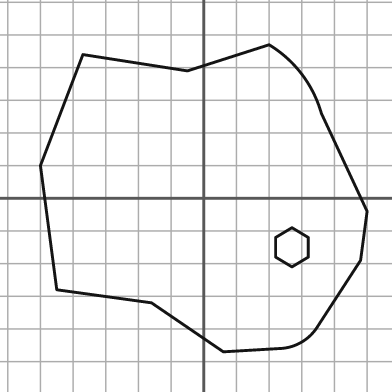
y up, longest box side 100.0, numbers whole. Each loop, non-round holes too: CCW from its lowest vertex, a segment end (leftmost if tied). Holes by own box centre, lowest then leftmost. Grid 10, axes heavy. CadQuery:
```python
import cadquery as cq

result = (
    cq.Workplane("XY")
    .moveTo(6.0, -47.0)
    .lineTo(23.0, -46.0)
    .threePointArc((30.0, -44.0), (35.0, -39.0))
    .lineTo(48.0, -19.0)
    .lineTo(50.0, -4.0)
    .lineTo(36.0, 26.0)
    .threePointArc((30.0, 38.0), (20.0, 47.0))
    .lineTo(-5.0, 39.0)
    .lineTo(-37.0, 44.0)
    .lineTo(-50.0, 10.0)
    .lineTo(-45.0, -28.0)
    .lineTo(-16.0, -32.0)
    .close()
    .moveTo(27.0, -21.0)
    .lineTo(32.0, -18.0)
    .lineTo(32.0, -12.0)
    .lineTo(27.0, -9.0)
    .lineTo(22.0, -12.0)
    .lineTo(22.0, -18.0)
    .close()
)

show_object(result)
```